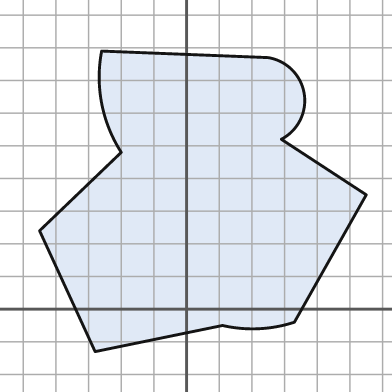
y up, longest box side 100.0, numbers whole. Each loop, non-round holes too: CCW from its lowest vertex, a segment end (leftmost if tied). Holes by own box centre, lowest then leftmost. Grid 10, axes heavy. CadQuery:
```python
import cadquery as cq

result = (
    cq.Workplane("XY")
    .moveTo(-28.0, -13.0)
    .lineTo(11.0, -5.0)
    .threePointArc((22.0, -6.0), (33.0, -4.0))
    .lineTo(55.0, 35.0)
    .lineTo(29.0, 52.0)
    .threePointArc((36.0, 66.0), (25.0, 77.0))
    .lineTo(-26.0, 79.0)
    .threePointArc((-26.0, 63.0), (-20.0, 48.0))
    .lineTo(-45.0, 24.0)
    .close()
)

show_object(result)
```